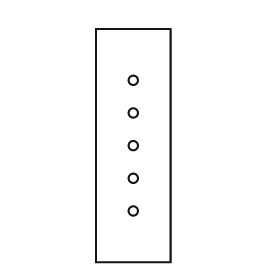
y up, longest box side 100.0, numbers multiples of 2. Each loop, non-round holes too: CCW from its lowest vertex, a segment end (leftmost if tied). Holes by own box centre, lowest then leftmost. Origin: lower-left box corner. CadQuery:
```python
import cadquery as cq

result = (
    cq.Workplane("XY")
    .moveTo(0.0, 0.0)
    .lineTo(32.0, 0.0)
    .lineTo(32.0, 100.0)
    .lineTo(0.0, 100.0)
    .close()
    .moveTo(16.0, 22.0)
    .circle(2.0)
    .moveTo(16.0, 36.0)
    .circle(2.0)
    .moveTo(16.0, 50.0)
    .circle(2.0)
    .moveTo(16.0, 64.0)
    .circle(2.0)
    .moveTo(16.0, 78.0)
    .circle(2.0)
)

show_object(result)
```